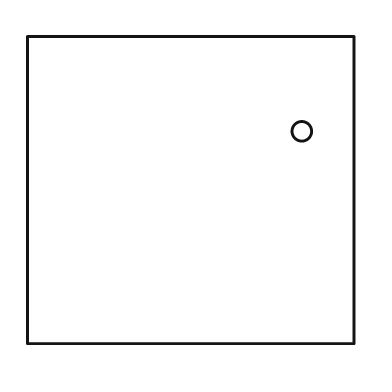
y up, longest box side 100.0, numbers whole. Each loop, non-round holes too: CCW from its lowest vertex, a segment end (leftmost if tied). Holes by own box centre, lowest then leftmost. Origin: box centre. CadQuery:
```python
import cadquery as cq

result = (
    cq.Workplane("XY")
    .moveTo(-50.0, -47.0)
    .lineTo(50.0, -47.0)
    .lineTo(50.0, 47.0)
    .lineTo(-50.0, 47.0)
    .close()
    .moveTo(34.0, 18.0)
    .circle(3.0)
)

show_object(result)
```